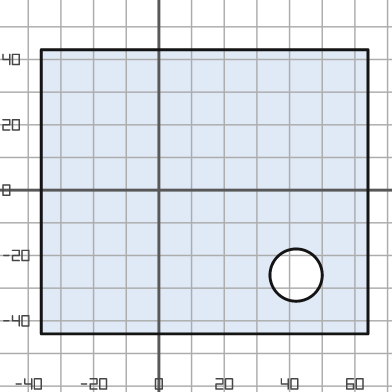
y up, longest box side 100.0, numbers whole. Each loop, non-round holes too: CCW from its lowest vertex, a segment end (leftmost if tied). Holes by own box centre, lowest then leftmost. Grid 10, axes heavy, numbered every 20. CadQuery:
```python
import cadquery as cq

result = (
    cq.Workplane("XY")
    .moveTo(-36.0, -44.0)
    .lineTo(64.0, -44.0)
    .lineTo(64.0, 43.0)
    .lineTo(-36.0, 43.0)
    .close()
    .moveTo(42.0, -26.0)
    .circle(8.0)
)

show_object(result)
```